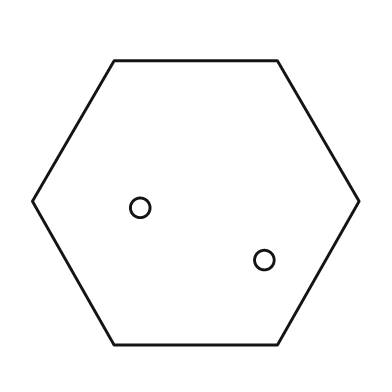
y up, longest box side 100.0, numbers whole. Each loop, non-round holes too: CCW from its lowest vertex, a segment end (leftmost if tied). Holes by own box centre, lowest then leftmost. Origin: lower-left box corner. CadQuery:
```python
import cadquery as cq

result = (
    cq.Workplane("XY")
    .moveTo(25.0, 0.0)
    .lineTo(75.0, 0.0)
    .lineTo(100.0, 44.0)
    .lineTo(75.0, 87.0)
    .lineTo(25.0, 87.0)
    .lineTo(0.0, 44.0)
    .close()
    .moveTo(71.0, 26.0)
    .circle(3.0)
    .moveTo(33.0, 42.0)
    .circle(3.0)
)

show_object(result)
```